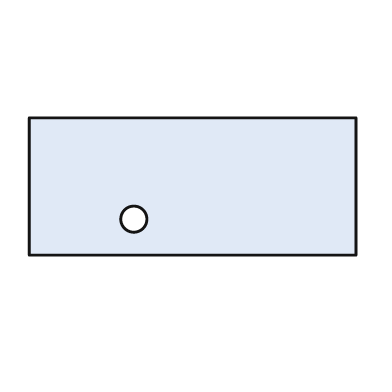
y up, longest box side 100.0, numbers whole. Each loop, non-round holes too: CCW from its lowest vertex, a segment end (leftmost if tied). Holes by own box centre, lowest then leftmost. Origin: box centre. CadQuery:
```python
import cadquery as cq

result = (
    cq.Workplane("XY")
    .moveTo(-50.0, -21.0)
    .lineTo(50.0, -21.0)
    .lineTo(50.0, 21.0)
    .lineTo(-50.0, 21.0)
    .close()
    .moveTo(-18.0, -10.0)
    .circle(4.0)
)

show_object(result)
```